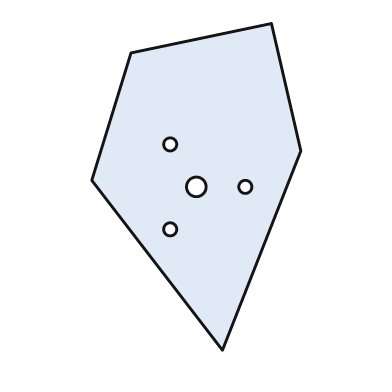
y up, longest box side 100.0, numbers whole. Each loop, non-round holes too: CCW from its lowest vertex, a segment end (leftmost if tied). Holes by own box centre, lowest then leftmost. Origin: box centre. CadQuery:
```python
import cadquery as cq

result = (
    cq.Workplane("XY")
    .moveTo(8.0, -50.0)
    .lineTo(32.0, 11.0)
    .lineTo(23.0, 50.0)
    .lineTo(-20.0, 41.0)
    .lineTo(-32.0, 2.0)
    .close()
    .moveTo(-8.0, -13.0)
    .circle(2.0)
    .moveTo(0.0, 0.0)
    .circle(3.0)
    .moveTo(15.0, 0.0)
    .circle(2.0)
    .moveTo(-8.0, 13.0)
    .circle(2.0)
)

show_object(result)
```